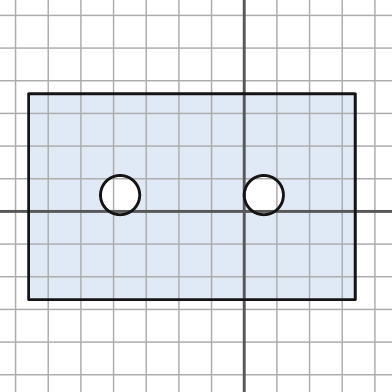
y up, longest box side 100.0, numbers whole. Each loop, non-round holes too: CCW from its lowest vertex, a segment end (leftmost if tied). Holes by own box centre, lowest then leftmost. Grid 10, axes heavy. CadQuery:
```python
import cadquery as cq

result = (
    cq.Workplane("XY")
    .moveTo(-66.0, -27.0)
    .lineTo(34.0, -27.0)
    .lineTo(34.0, 36.0)
    .lineTo(-66.0, 36.0)
    .close()
    .moveTo(-38.0, 5.0)
    .circle(6.0)
    .moveTo(6.0, 5.0)
    .circle(6.0)
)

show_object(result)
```